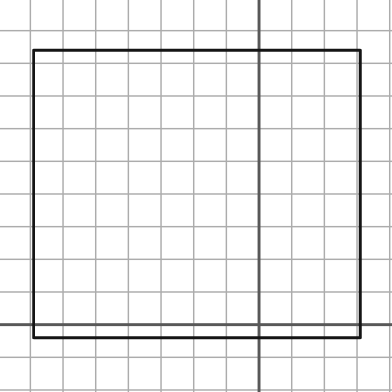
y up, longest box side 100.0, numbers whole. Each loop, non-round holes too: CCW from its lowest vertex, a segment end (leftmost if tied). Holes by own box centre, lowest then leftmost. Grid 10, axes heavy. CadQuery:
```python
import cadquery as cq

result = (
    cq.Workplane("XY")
    .moveTo(-69.0, -4.0)
    .lineTo(31.0, -4.0)
    .lineTo(31.0, 84.0)
    .lineTo(-69.0, 84.0)
    .close()
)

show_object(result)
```